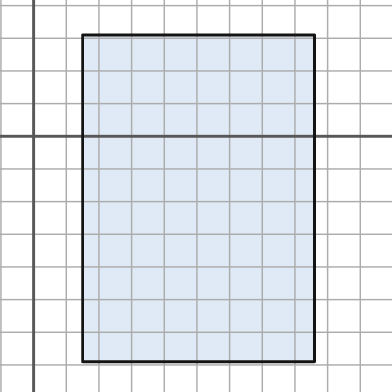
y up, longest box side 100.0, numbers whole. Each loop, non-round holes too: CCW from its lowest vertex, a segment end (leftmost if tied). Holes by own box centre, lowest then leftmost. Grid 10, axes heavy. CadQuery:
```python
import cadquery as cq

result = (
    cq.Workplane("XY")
    .moveTo(15.0, -69.0)
    .lineTo(86.0, -69.0)
    .lineTo(86.0, 31.0)
    .lineTo(15.0, 31.0)
    .close()
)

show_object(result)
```